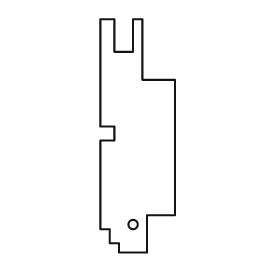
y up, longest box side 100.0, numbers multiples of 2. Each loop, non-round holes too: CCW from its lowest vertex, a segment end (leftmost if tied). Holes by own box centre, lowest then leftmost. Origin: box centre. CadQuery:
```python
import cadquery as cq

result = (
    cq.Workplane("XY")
    .moveTo(-8.0, -50.0)
    .lineTo(4.0, -50.0)
    .lineTo(4.0, -34.0)
    .lineTo(16.0, -34.0)
    .lineTo(16.0, 24.0)
    .lineTo(2.0, 24.0)
    .lineTo(2.0, 50.0)
    .lineTo(-2.0, 50.0)
    .lineTo(-2.0, 36.0)
    .lineTo(-10.0, 36.0)
    .lineTo(-10.0, 50.0)
    .lineTo(-16.0, 50.0)
    .lineTo(-16.0, 4.0)
    .lineTo(-10.0, 4.0)
    .lineTo(-10.0, -2.0)
    .lineTo(-16.0, -2.0)
    .lineTo(-16.0, -40.0)
    .lineTo(-12.0, -40.0)
    .lineTo(-12.0, -46.0)
    .lineTo(-8.0, -46.0)
    .close()
    .moveTo(-2.0, -38.0)
    .circle(2.0)
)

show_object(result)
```